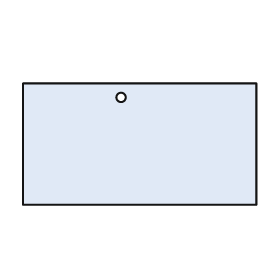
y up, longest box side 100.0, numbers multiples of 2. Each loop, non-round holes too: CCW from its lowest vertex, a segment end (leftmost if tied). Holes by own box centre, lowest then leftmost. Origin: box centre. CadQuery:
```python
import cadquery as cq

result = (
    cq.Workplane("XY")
    .moveTo(-50.0, -26.0)
    .lineTo(50.0, -26.0)
    .lineTo(50.0, 26.0)
    .lineTo(-50.0, 26.0)
    .close()
    .moveTo(-8.0, 20.0)
    .circle(2.0)
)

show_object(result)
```